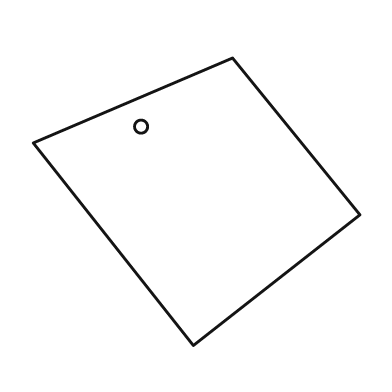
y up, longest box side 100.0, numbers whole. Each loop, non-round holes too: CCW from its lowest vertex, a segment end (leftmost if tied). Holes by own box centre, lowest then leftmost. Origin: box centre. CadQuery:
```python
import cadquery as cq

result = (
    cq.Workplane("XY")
    .moveTo(-1.0, -44.0)
    .lineTo(50.0, -4.0)
    .lineTo(11.0, 44.0)
    .lineTo(-50.0, 18.0)
    .close()
    .moveTo(-17.0, 23.0)
    .circle(2.0)
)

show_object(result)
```